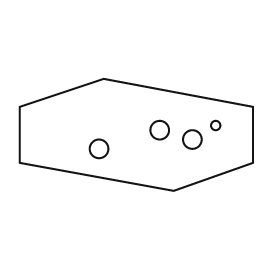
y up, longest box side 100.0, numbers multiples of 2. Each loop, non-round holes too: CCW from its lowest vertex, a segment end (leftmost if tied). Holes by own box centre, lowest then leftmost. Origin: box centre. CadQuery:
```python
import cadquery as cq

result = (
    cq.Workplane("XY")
    .moveTo(16.0, -24.0)
    .lineTo(50.0, -12.0)
    .lineTo(50.0, 12.0)
    .lineTo(-14.0, 24.0)
    .lineTo(-50.0, 12.0)
    .lineTo(-50.0, -12.0)
    .close()
    .moveTo(-16.0, -6.0)
    .circle(4.0)
    .moveTo(24.0, -2.0)
    .circle(4.0)
    .moveTo(10.0, 2.0)
    .circle(4.0)
    .moveTo(34.0, 4.0)
    .circle(2.0)
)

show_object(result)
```